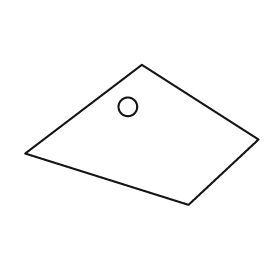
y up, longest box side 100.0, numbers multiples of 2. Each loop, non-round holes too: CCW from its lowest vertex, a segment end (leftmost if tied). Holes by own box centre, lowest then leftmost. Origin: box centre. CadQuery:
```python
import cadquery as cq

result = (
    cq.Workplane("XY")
    .moveTo(20.0, -30.0)
    .lineTo(50.0, -2.0)
    .lineTo(0.0, 30.0)
    .lineTo(-50.0, -8.0)
    .close()
    .moveTo(-6.0, 12.0)
    .circle(4.0)
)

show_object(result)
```